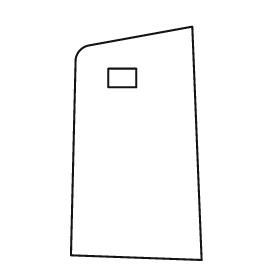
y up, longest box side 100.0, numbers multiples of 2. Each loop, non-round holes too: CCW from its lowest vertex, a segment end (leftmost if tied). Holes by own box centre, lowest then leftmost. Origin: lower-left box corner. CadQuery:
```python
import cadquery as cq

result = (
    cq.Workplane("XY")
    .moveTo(56.0, 0.0)
    .lineTo(52.0, 100.0)
    .lineTo(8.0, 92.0)
    .threePointArc((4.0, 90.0), (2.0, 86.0))
    .lineTo(0.0, 2.0)
    .close()
    .moveTo(16.0, 74.0)
    .lineTo(28.0, 74.0)
    .lineTo(28.0, 82.0)
    .lineTo(16.0, 82.0)
    .close()
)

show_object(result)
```